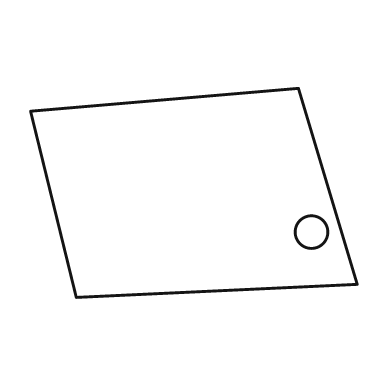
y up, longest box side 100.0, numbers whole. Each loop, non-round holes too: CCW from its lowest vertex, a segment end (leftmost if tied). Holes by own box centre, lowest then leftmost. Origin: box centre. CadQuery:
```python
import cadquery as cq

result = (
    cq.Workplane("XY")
    .moveTo(-36.0, -32.0)
    .lineTo(50.0, -28.0)
    .lineTo(32.0, 32.0)
    .lineTo(-50.0, 25.0)
    .close()
    .moveTo(36.0, -12.0)
    .circle(5.0)
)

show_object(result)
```